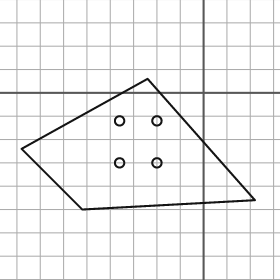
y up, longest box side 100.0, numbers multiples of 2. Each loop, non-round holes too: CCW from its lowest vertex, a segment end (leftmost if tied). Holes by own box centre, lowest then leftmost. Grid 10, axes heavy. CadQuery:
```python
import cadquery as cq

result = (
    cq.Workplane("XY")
    .moveTo(-52.0, -50.0)
    .lineTo(22.0, -46.0)
    .lineTo(-24.0, 6.0)
    .lineTo(-78.0, -24.0)
    .close()
    .moveTo(-36.0, -30.0)
    .circle(2.0)
    .moveTo(-20.0, -30.0)
    .circle(2.0)
    .moveTo(-36.0, -12.0)
    .circle(2.0)
    .moveTo(-20.0, -12.0)
    .circle(2.0)
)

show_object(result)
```